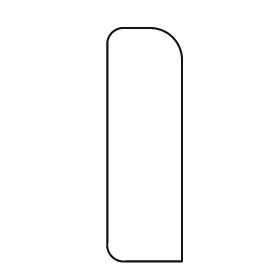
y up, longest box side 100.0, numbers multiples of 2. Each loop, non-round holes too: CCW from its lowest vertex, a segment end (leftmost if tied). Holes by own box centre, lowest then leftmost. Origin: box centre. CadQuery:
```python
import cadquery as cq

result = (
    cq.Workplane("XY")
    .moveTo(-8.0, -50.0)
    .lineTo(16.0, -50.0)
    .lineTo(16.0, 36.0)
    .threePointArc((12.0, 46.0), (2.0, 50.0))
    .lineTo(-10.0, 50.0)
    .threePointArc((-14.0, 48.0), (-16.0, 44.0))
    .lineTo(-16.0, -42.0)
    .threePointArc((-14.0, -48.0), (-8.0, -50.0))
    .close()
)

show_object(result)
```